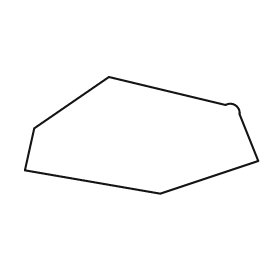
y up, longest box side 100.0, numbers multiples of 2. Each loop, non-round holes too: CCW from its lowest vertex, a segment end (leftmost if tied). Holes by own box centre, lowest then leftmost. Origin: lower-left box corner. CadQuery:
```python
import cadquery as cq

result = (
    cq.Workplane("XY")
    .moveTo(58.0, 0.0)
    .lineTo(100.0, 14.0)
    .lineTo(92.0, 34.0)
    .threePointArc((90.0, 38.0), (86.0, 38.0))
    .lineTo(36.0, 50.0)
    .lineTo(4.0, 28.0)
    .lineTo(0.0, 10.0)
    .close()
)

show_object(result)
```